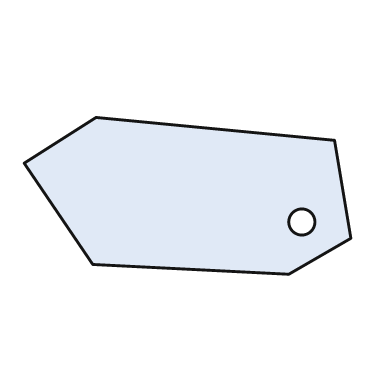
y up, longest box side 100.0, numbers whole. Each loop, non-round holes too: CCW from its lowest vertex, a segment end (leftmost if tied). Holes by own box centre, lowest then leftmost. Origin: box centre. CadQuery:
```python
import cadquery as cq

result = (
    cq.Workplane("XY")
    .moveTo(31.0, -24.0)
    .lineTo(50.0, -13.0)
    .lineTo(45.0, 17.0)
    .lineTo(-28.0, 24.0)
    .lineTo(-50.0, 10.0)
    .lineTo(-29.0, -21.0)
    .close()
    .moveTo(35.0, -8.0)
    .circle(4.0)
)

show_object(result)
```